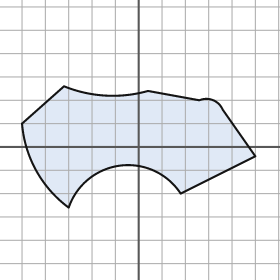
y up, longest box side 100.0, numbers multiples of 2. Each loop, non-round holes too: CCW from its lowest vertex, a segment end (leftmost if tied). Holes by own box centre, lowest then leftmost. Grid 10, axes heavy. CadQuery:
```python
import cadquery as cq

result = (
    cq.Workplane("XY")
    .moveTo(-30.0, -26.0)
    .threePointArc((-8.0, -8.0), (18.0, -20.0))
    .lineTo(50.0, -4.0)
    .lineTo(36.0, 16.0)
    .threePointArc((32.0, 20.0), (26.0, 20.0))
    .lineTo(4.0, 24.0)
    .threePointArc((-14.0, 22.0), (-32.0, 26.0))
    .lineTo(-50.0, 10.0)
    .threePointArc((-44.0, -10.0), (-30.0, -26.0))
    .close()
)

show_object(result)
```